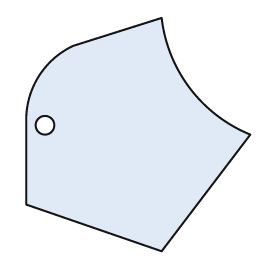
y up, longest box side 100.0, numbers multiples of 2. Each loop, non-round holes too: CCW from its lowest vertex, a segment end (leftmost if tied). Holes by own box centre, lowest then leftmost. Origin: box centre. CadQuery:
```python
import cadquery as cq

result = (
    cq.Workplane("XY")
    .moveTo(10.0, -50.0)
    .lineTo(48.0, 0.0)
    .threePointArc((22.0, 20.0), (10.0, 50.0))
    .lineTo(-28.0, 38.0)
    .threePointArc((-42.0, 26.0), (-48.0, 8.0))
    .lineTo(-48.0, -30.0)
    .close()
    .moveTo(-40.0, 4.0)
    .circle(4.0)
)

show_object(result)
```